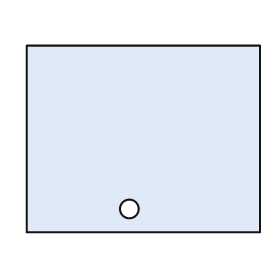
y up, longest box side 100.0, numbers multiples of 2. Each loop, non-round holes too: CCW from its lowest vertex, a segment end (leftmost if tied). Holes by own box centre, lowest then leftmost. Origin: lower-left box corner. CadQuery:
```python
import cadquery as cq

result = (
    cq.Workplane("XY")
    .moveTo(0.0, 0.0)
    .lineTo(100.0, 0.0)
    .lineTo(100.0, 80.0)
    .lineTo(0.0, 80.0)
    .close()
    .moveTo(44.0, 10.0)
    .circle(4.0)
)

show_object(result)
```